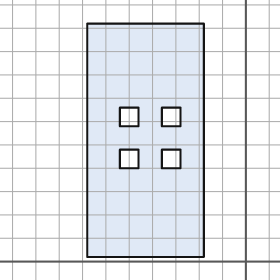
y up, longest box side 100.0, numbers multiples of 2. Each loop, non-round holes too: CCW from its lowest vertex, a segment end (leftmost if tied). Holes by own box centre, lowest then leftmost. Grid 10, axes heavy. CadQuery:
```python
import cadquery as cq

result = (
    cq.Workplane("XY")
    .moveTo(-68.0, 2.0)
    .lineTo(-18.0, 2.0)
    .lineTo(-18.0, 102.0)
    .lineTo(-68.0, 102.0)
    .close()
    .moveTo(-54.0, 40.0)
    .lineTo(-46.0, 40.0)
    .lineTo(-46.0, 48.0)
    .lineTo(-54.0, 48.0)
    .close()
    .moveTo(-36.0, 40.0)
    .lineTo(-28.0, 40.0)
    .lineTo(-28.0, 48.0)
    .lineTo(-36.0, 48.0)
    .close()
    .moveTo(-54.0, 58.0)
    .lineTo(-46.0, 58.0)
    .lineTo(-46.0, 66.0)
    .lineTo(-54.0, 66.0)
    .close()
    .moveTo(-36.0, 58.0)
    .lineTo(-28.0, 58.0)
    .lineTo(-28.0, 66.0)
    .lineTo(-36.0, 66.0)
    .close()
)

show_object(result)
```